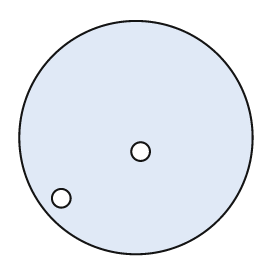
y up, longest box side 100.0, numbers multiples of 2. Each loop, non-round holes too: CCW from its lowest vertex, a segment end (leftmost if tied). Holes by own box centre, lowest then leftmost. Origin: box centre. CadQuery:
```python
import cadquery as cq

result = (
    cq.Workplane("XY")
    .moveTo(0.0, 0.0)
    .circle(50.0)
    .moveTo(-32.0, -26.0)
    .circle(4.0)
    .moveTo(2.0, -6.0)
    .circle(4.0)
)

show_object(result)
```